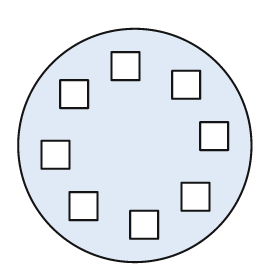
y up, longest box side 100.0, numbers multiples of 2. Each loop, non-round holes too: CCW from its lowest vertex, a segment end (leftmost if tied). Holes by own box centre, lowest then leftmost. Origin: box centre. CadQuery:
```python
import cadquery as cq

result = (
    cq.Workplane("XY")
    .moveTo(0.0, 0.0)
    .circle(50.0)
    .moveTo(-2.0, -40.0)
    .lineTo(10.0, -40.0)
    .lineTo(10.0, -28.0)
    .lineTo(-2.0, -28.0)
    .close()
    .moveTo(-28.0, -32.0)
    .lineTo(-16.0, -32.0)
    .lineTo(-16.0, -20.0)
    .lineTo(-28.0, -20.0)
    .close()
    .moveTo(20.0, -28.0)
    .lineTo(32.0, -28.0)
    .lineTo(32.0, -16.0)
    .lineTo(20.0, -16.0)
    .close()
    .moveTo(-40.0, -10.0)
    .lineTo(-28.0, -10.0)
    .lineTo(-28.0, 2.0)
    .lineTo(-40.0, 2.0)
    .close()
    .moveTo(28.0, -2.0)
    .lineTo(40.0, -2.0)
    .lineTo(40.0, 10.0)
    .lineTo(28.0, 10.0)
    .close()
    .moveTo(-32.0, 16.0)
    .lineTo(-20.0, 16.0)
    .lineTo(-20.0, 28.0)
    .lineTo(-32.0, 28.0)
    .close()
    .moveTo(16.0, 20.0)
    .lineTo(28.0, 20.0)
    .lineTo(28.0, 32.0)
    .lineTo(16.0, 32.0)
    .close()
    .moveTo(-10.0, 28.0)
    .lineTo(2.0, 28.0)
    .lineTo(2.0, 40.0)
    .lineTo(-10.0, 40.0)
    .close()
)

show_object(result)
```